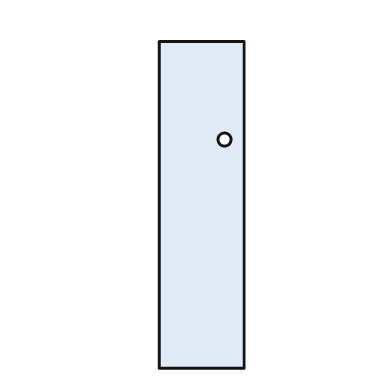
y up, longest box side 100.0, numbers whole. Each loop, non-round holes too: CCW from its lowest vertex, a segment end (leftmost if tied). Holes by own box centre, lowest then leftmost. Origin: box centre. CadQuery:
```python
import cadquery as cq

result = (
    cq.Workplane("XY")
    .moveTo(-13.0, -50.0)
    .lineTo(13.0, -50.0)
    .lineTo(13.0, 50.0)
    .lineTo(-13.0, 50.0)
    .close()
    .moveTo(7.0, 20.0)
    .circle(2.0)
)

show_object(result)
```